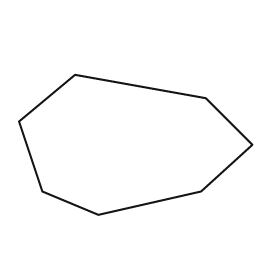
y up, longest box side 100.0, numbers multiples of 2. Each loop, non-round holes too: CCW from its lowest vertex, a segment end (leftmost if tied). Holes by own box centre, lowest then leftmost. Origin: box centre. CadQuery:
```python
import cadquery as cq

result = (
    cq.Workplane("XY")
    .moveTo(-16.0, -30.0)
    .lineTo(28.0, -20.0)
    .lineTo(50.0, 0.0)
    .lineTo(30.0, 20.0)
    .lineTo(-26.0, 30.0)
    .lineTo(-50.0, 10.0)
    .lineTo(-40.0, -20.0)
    .close()
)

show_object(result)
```